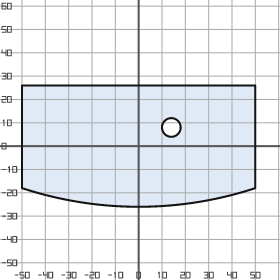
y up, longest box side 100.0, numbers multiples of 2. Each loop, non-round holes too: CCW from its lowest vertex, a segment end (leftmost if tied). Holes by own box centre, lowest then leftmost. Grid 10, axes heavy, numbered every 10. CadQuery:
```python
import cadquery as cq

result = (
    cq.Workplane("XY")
    .moveTo(-50.0, -18.0)
    .threePointArc((0.0, -26.0), (50.0, -18.0))
    .lineTo(50.0, 26.0)
    .lineTo(-50.0, 26.0)
    .close()
    .moveTo(14.0, 8.0)
    .circle(4.0)
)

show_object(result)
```